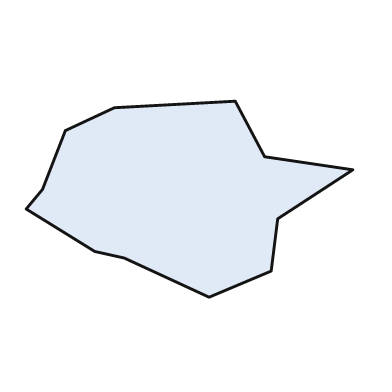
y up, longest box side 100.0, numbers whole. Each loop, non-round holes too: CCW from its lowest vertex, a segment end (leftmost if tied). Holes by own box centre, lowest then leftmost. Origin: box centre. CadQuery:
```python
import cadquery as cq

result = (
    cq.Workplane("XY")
    .moveTo(6.0, -30.0)
    .lineTo(25.0, -22.0)
    .lineTo(27.0, -6.0)
    .lineTo(50.0, 9.0)
    .lineTo(23.0, 13.0)
    .lineTo(14.0, 30.0)
    .lineTo(-23.0, 28.0)
    .lineTo(-38.0, 21.0)
    .lineTo(-45.0, 3.0)
    .lineTo(-50.0, -3.0)
    .lineTo(-29.0, -16.0)
    .lineTo(-20.0, -18.0)
    .close()
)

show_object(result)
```